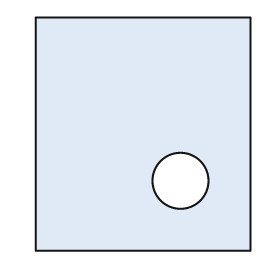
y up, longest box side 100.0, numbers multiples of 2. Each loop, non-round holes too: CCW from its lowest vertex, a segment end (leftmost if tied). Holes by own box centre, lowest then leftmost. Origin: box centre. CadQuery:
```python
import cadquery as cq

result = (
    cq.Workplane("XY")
    .moveTo(-46.0, -50.0)
    .lineTo(46.0, -50.0)
    .lineTo(46.0, 50.0)
    .lineTo(-46.0, 50.0)
    .close()
    .moveTo(16.0, -20.0)
    .circle(12.0)
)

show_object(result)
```